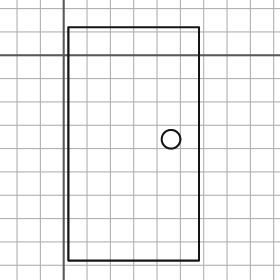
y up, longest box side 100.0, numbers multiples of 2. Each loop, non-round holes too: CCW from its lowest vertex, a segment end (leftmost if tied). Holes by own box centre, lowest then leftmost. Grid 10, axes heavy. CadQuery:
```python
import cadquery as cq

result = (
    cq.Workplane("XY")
    .moveTo(2.0, -88.0)
    .lineTo(58.0, -88.0)
    .lineTo(58.0, 12.0)
    .lineTo(2.0, 12.0)
    .close()
    .moveTo(46.0, -36.0)
    .circle(4.0)
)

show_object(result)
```